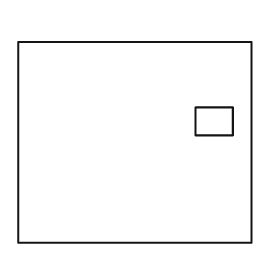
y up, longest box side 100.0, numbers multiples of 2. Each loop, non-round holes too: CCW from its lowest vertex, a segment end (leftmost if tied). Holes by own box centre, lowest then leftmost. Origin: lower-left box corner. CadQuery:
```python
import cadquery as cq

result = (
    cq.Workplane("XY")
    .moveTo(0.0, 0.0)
    .lineTo(100.0, 0.0)
    .lineTo(100.0, 86.0)
    .lineTo(0.0, 86.0)
    .close()
    .moveTo(76.0, 46.0)
    .lineTo(92.0, 46.0)
    .lineTo(92.0, 58.0)
    .lineTo(76.0, 58.0)
    .close()
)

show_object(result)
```